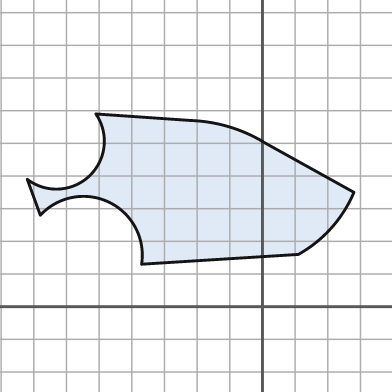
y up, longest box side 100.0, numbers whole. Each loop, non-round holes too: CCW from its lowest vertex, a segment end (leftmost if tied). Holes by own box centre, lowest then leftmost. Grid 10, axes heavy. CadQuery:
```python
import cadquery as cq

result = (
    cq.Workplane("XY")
    .moveTo(-37.0, 13.0)
    .lineTo(11.0, 16.0)
    .threePointArc((21.0, 24.0), (28.0, 35.0))
    .lineTo(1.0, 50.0)
    .threePointArc((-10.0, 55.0), (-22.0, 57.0))
    .lineTo(-51.0, 59.0)
    .threePointArc((-53.0, 40.0), (-72.0, 39.0))
    .lineTo(-68.0, 28.0)
    .threePointArc((-47.0, 32.0), (-37.0, 13.0))
    .close()
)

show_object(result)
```